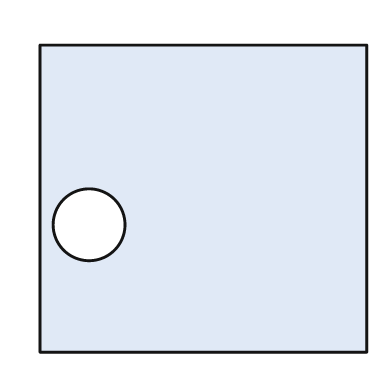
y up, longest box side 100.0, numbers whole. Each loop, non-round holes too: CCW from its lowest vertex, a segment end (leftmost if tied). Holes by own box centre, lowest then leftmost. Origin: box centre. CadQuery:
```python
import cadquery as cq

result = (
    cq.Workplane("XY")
    .moveTo(-50.0, -47.0)
    .lineTo(50.0, -47.0)
    .lineTo(50.0, 47.0)
    .lineTo(-50.0, 47.0)
    .close()
    .moveTo(-35.0, -8.0)
    .circle(11.0)
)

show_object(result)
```